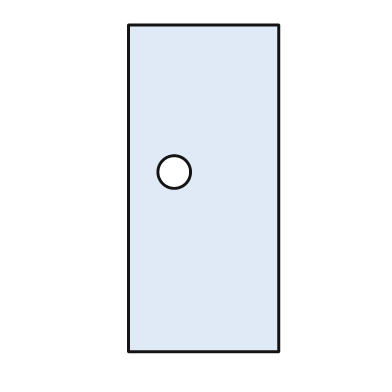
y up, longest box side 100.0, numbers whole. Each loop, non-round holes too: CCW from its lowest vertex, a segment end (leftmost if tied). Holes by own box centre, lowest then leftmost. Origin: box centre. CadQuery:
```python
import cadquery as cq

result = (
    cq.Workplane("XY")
    .moveTo(-23.0, -50.0)
    .lineTo(23.0, -50.0)
    .lineTo(23.0, 50.0)
    .lineTo(-23.0, 50.0)
    .close()
    .moveTo(-9.0, 5.0)
    .circle(5.0)
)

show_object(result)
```